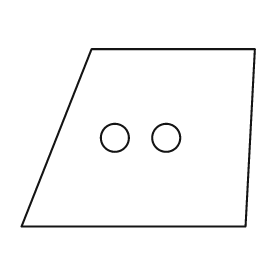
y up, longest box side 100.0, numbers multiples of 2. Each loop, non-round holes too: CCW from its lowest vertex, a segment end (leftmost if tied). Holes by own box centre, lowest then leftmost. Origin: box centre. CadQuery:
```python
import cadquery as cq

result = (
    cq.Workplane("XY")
    .moveTo(-50.0, -38.0)
    .lineTo(46.0, -38.0)
    .lineTo(50.0, 38.0)
    .lineTo(-20.0, 38.0)
    .close()
    .moveTo(-10.0, 0.0)
    .circle(6.0)
    .moveTo(12.0, 0.0)
    .circle(6.0)
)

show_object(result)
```